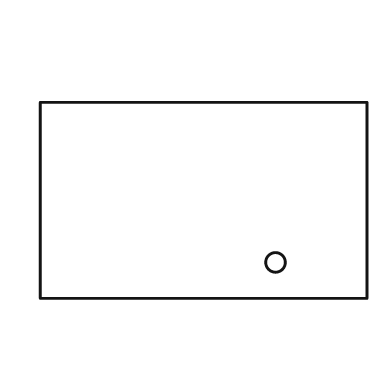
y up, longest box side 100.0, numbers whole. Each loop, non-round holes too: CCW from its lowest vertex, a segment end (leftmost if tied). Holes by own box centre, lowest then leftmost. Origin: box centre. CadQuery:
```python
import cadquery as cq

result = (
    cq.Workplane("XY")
    .moveTo(-50.0, -30.0)
    .lineTo(50.0, -30.0)
    .lineTo(50.0, 30.0)
    .lineTo(-50.0, 30.0)
    .close()
    .moveTo(22.0, -19.0)
    .circle(3.0)
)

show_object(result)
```